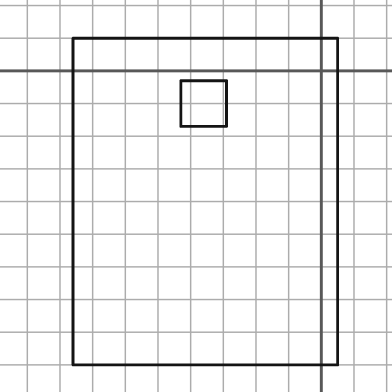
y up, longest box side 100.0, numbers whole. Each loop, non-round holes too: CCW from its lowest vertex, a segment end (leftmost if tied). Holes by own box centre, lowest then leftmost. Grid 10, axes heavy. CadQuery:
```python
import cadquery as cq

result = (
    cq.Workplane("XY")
    .moveTo(-76.0, -90.0)
    .lineTo(5.0, -90.0)
    .lineTo(5.0, 10.0)
    .lineTo(-76.0, 10.0)
    .close()
    .moveTo(-43.0, -17.0)
    .lineTo(-29.0, -17.0)
    .lineTo(-29.0, -3.0)
    .lineTo(-43.0, -3.0)
    .close()
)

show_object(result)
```